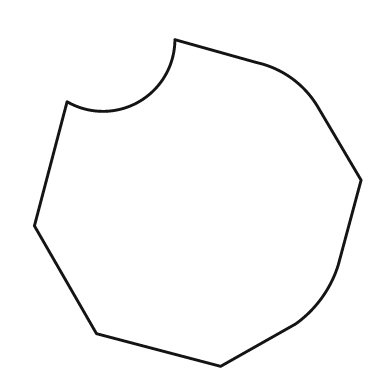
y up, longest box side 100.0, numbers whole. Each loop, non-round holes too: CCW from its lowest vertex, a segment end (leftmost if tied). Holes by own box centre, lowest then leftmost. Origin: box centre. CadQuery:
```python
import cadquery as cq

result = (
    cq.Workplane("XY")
    .moveTo(7.0, -50.0)
    .lineTo(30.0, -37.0)
    .threePointArc((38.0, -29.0), (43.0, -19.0))
    .lineTo(50.0, 7.0)
    .lineTo(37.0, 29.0)
    .threePointArc((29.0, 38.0), (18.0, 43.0))
    .lineTo(-7.0, 50.0)
    .threePointArc((-18.0, 31.0), (-40.0, 31.0))
    .lineTo(-50.0, -7.0)
    .lineTo(-31.0, -40.0)
    .close()
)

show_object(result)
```